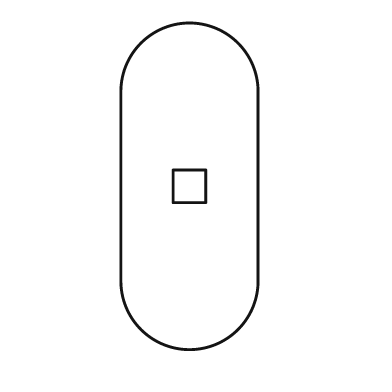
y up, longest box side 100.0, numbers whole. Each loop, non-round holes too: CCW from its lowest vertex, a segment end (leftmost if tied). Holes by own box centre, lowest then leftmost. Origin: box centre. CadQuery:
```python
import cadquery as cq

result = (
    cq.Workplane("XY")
    .moveTo(-21.0, -29.0)
    .threePointArc((0.0, -50.0), (21.0, -29.0))
    .lineTo(21.0, 29.0)
    .threePointArc((0.0, 50.0), (-21.0, 29.0))
    .close()
    .moveTo(-5.0, -5.0)
    .lineTo(5.0, -5.0)
    .lineTo(5.0, 5.0)
    .lineTo(-5.0, 5.0)
    .close()
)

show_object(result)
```